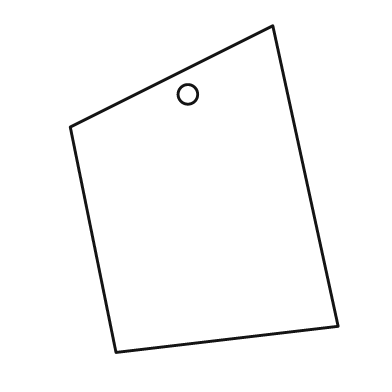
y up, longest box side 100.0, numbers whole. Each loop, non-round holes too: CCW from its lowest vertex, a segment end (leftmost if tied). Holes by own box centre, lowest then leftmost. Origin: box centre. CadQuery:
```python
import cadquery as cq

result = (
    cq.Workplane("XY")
    .moveTo(-27.0, -50.0)
    .lineTo(41.0, -42.0)
    .lineTo(21.0, 50.0)
    .lineTo(-41.0, 19.0)
    .close()
    .moveTo(-5.0, 29.0)
    .circle(3.0)
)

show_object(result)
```